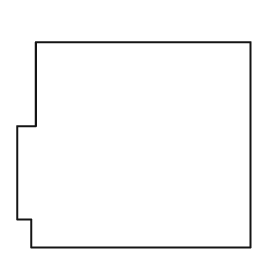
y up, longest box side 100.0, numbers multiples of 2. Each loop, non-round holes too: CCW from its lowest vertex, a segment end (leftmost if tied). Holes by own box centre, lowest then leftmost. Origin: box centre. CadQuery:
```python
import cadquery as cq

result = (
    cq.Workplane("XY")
    .moveTo(-44.0, -44.0)
    .lineTo(50.0, -44.0)
    .lineTo(50.0, 44.0)
    .lineTo(-42.0, 44.0)
    .lineTo(-42.0, 8.0)
    .lineTo(-50.0, 8.0)
    .lineTo(-50.0, -32.0)
    .lineTo(-44.0, -32.0)
    .close()
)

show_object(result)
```